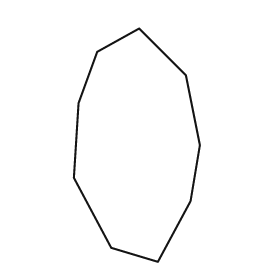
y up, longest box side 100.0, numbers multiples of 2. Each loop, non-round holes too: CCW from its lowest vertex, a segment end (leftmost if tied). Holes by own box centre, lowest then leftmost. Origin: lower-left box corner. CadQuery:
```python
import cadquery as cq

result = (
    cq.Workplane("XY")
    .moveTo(36.0, 0.0)
    .lineTo(50.0, 26.0)
    .lineTo(54.0, 50.0)
    .lineTo(48.0, 80.0)
    .lineTo(28.0, 100.0)
    .lineTo(10.0, 90.0)
    .lineTo(2.0, 68.0)
    .lineTo(0.0, 36.0)
    .lineTo(16.0, 6.0)
    .close()
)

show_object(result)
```